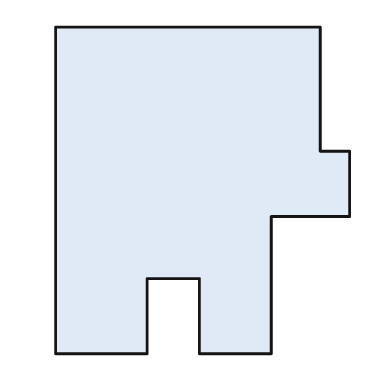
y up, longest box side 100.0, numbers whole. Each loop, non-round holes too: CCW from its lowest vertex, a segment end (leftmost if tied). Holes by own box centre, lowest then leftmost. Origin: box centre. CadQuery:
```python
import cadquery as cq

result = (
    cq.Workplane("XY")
    .moveTo(-45.0, -50.0)
    .lineTo(-17.0, -50.0)
    .lineTo(-17.0, -27.0)
    .lineTo(-1.0, -27.0)
    .lineTo(-1.0, -50.0)
    .lineTo(21.0, -50.0)
    .lineTo(21.0, -8.0)
    .lineTo(45.0, -8.0)
    .lineTo(45.0, 12.0)
    .lineTo(36.0, 12.0)
    .lineTo(36.0, 50.0)
    .lineTo(-45.0, 50.0)
    .close()
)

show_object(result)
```